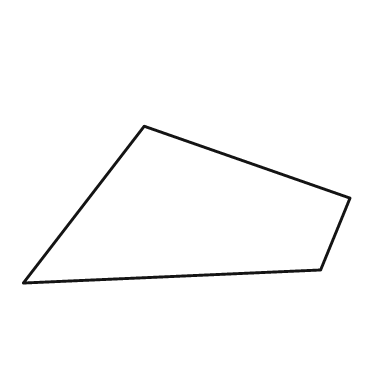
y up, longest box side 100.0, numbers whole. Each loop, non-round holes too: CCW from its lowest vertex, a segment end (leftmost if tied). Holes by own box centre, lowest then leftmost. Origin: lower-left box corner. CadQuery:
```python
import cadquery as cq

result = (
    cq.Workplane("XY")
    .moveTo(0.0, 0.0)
    .lineTo(91.0, 4.0)
    .lineTo(100.0, 26.0)
    .lineTo(37.0, 48.0)
    .close()
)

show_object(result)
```